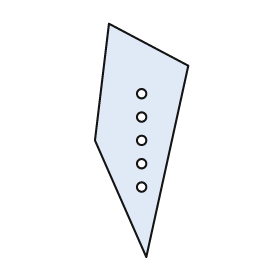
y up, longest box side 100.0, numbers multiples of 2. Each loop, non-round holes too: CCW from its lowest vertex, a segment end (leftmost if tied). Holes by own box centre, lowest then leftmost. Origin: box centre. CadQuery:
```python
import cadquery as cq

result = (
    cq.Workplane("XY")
    .moveTo(2.0, -50.0)
    .lineTo(20.0, 32.0)
    .lineTo(-14.0, 50.0)
    .lineTo(-20.0, 0.0)
    .close()
    .moveTo(0.0, -20.0)
    .circle(2.0)
    .moveTo(0.0, -10.0)
    .circle(2.0)
    .moveTo(0.0, 0.0)
    .circle(2.0)
    .moveTo(0.0, 10.0)
    .circle(2.0)
    .moveTo(0.0, 20.0)
    .circle(2.0)
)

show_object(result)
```